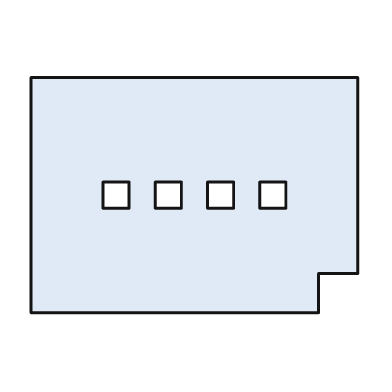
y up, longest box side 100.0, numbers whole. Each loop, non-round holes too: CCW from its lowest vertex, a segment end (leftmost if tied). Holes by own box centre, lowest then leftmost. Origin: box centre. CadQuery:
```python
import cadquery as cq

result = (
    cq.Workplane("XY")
    .moveTo(-50.0, -36.0)
    .lineTo(38.0, -36.0)
    .lineTo(38.0, -24.0)
    .lineTo(50.0, -24.0)
    .lineTo(50.0, 36.0)
    .lineTo(-50.0, 36.0)
    .close()
    .moveTo(-28.0, -4.0)
    .lineTo(-20.0, -4.0)
    .lineTo(-20.0, 4.0)
    .lineTo(-28.0, 4.0)
    .close()
    .moveTo(-12.0, -4.0)
    .lineTo(-4.0, -4.0)
    .lineTo(-4.0, 4.0)
    .lineTo(-12.0, 4.0)
    .close()
    .moveTo(4.0, -4.0)
    .lineTo(12.0, -4.0)
    .lineTo(12.0, 4.0)
    .lineTo(4.0, 4.0)
    .close()
    .moveTo(20.0, -4.0)
    .lineTo(28.0, -4.0)
    .lineTo(28.0, 4.0)
    .lineTo(20.0, 4.0)
    .close()
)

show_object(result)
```